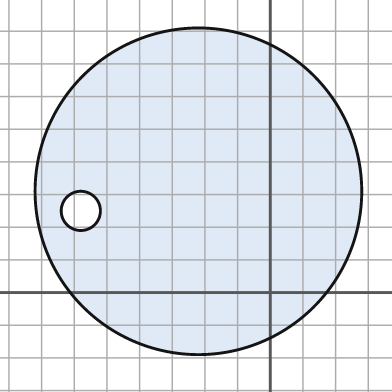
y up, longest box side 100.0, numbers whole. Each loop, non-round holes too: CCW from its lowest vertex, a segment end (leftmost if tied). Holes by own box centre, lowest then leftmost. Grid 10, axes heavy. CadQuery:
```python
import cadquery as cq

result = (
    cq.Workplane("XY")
    .moveTo(-22.0, 31.0)
    .circle(50.0)
    .moveTo(-58.0, 25.0)
    .circle(6.0)
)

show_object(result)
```